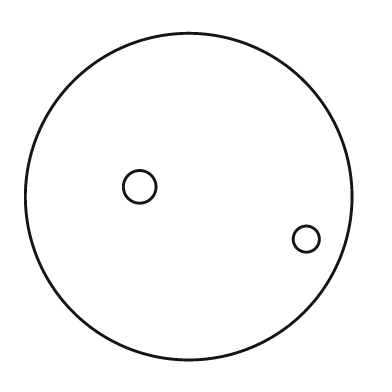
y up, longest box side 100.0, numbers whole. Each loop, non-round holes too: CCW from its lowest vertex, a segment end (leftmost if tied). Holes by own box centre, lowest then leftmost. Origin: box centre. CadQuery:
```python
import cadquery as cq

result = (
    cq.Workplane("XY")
    .moveTo(0.0, 0.0)
    .circle(50.0)
    .moveTo(36.0, -13.0)
    .circle(4.0)
    .moveTo(-15.0, 3.0)
    .circle(5.0)
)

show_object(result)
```